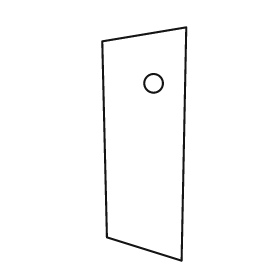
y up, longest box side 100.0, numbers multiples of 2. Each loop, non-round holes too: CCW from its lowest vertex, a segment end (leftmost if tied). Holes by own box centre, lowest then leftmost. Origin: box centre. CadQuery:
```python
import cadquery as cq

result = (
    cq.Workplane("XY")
    .moveTo(16.0, -50.0)
    .lineTo(18.0, 50.0)
    .lineTo(-18.0, 44.0)
    .lineTo(-16.0, -40.0)
    .close()
    .moveTo(4.0, 26.0)
    .circle(4.0)
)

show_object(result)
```